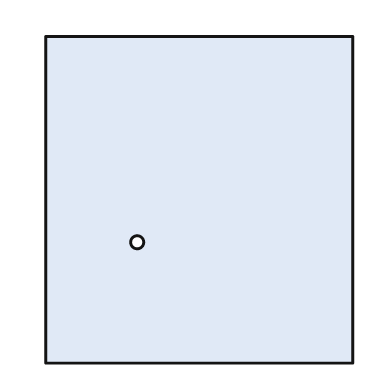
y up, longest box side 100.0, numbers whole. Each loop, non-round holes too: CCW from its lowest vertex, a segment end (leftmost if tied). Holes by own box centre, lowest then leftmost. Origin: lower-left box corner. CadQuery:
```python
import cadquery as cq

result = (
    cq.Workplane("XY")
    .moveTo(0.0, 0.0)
    .lineTo(94.0, 0.0)
    .lineTo(94.0, 100.0)
    .lineTo(0.0, 100.0)
    .close()
    .moveTo(28.0, 37.0)
    .circle(2.0)
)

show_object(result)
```